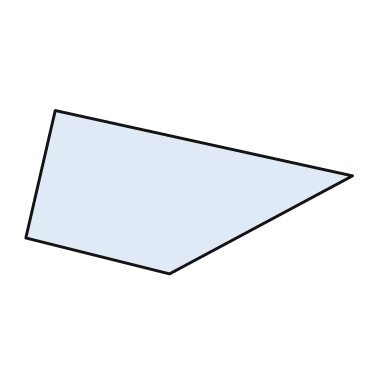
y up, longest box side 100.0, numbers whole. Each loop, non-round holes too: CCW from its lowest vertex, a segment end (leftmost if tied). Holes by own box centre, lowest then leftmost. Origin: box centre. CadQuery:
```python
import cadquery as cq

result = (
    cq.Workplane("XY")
    .moveTo(-6.0, -25.0)
    .lineTo(50.0, 5.0)
    .lineTo(-41.0, 25.0)
    .lineTo(-50.0, -14.0)
    .close()
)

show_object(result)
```